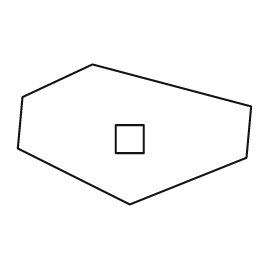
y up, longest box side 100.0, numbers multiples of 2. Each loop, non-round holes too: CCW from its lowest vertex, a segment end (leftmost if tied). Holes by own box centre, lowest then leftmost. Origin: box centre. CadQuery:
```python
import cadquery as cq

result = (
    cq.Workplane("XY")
    .moveTo(-2.0, -30.0)
    .lineTo(48.0, -10.0)
    .lineTo(50.0, 12.0)
    .lineTo(-18.0, 30.0)
    .lineTo(-48.0, 16.0)
    .lineTo(-50.0, -6.0)
    .close()
    .moveTo(-8.0, -8.0)
    .lineTo(4.0, -8.0)
    .lineTo(4.0, 4.0)
    .lineTo(-8.0, 4.0)
    .close()
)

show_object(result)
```